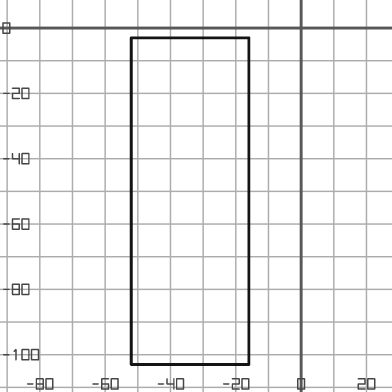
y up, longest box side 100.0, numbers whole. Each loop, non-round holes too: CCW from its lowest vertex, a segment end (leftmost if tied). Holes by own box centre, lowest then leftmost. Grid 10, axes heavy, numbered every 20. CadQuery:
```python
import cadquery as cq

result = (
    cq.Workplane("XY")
    .moveTo(-52.0, -103.0)
    .lineTo(-16.0, -103.0)
    .lineTo(-16.0, -3.0)
    .lineTo(-52.0, -3.0)
    .close()
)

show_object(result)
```